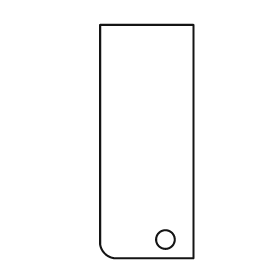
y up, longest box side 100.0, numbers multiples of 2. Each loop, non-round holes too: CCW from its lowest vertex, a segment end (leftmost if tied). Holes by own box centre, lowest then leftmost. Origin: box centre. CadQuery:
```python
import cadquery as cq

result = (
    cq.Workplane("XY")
    .moveTo(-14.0, -50.0)
    .lineTo(20.0, -50.0)
    .lineTo(20.0, 50.0)
    .lineTo(-20.0, 50.0)
    .lineTo(-20.0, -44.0)
    .threePointArc((-18.0, -48.0), (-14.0, -50.0))
    .close()
    .moveTo(8.0, -42.0)
    .circle(4.0)
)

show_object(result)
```